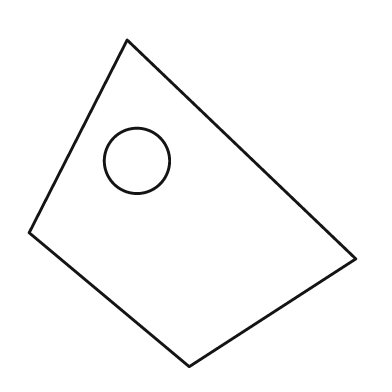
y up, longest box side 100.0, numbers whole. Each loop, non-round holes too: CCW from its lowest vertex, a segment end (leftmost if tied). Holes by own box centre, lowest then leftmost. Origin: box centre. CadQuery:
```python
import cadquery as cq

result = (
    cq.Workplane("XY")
    .moveTo(-1.0, -50.0)
    .lineTo(50.0, -17.0)
    .lineTo(-20.0, 50.0)
    .lineTo(-50.0, -9.0)
    .close()
    .moveTo(-17.0, 13.0)
    .circle(10.0)
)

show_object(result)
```